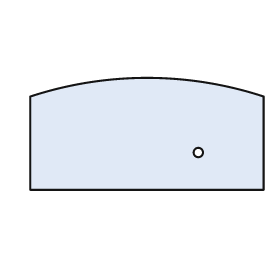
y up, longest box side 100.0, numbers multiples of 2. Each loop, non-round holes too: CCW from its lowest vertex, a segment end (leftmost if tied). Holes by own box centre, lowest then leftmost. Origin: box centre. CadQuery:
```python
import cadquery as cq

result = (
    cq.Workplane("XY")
    .moveTo(-50.0, -24.0)
    .lineTo(50.0, -24.0)
    .lineTo(50.0, 16.0)
    .threePointArc((0.0, 24.0), (-50.0, 16.0))
    .close()
    .moveTo(22.0, -8.0)
    .circle(2.0)
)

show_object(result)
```